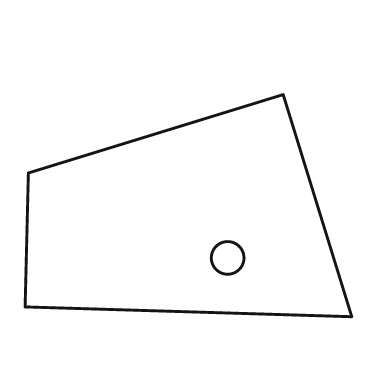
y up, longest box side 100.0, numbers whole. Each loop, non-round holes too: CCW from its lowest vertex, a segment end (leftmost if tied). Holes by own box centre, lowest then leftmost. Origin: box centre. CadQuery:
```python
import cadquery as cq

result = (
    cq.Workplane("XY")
    .moveTo(50.0, -34.0)
    .lineTo(29.0, 34.0)
    .lineTo(-49.0, 10.0)
    .lineTo(-50.0, -31.0)
    .close()
    .moveTo(12.0, -16.0)
    .circle(5.0)
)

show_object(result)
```